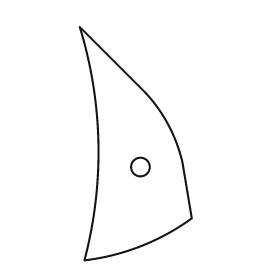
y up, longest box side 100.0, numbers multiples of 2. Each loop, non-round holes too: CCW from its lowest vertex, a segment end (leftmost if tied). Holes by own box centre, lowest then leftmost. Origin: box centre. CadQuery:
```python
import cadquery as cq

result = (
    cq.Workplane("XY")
    .moveTo(-22.0, -50.0)
    .threePointArc((2.0, -44.0), (24.0, -32.0))
    .lineTo(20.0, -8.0)
    .threePointArc((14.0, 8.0), (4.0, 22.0))
    .lineTo(-24.0, 50.0)
    .threePointArc((-16.0, 0.0), (-22.0, -50.0))
    .close()
    .moveTo(2.0, -10.0)
    .circle(4.0)
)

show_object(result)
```